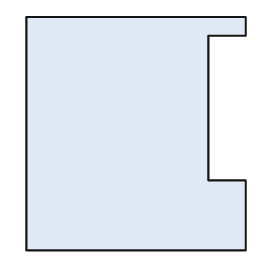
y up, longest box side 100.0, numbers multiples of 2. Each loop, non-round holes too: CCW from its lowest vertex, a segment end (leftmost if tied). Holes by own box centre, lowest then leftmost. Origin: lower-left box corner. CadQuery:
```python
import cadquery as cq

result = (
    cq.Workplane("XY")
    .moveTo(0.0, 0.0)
    .lineTo(94.0, 0.0)
    .lineTo(94.0, 30.0)
    .lineTo(78.0, 30.0)
    .lineTo(78.0, 92.0)
    .lineTo(94.0, 92.0)
    .lineTo(94.0, 100.0)
    .lineTo(0.0, 100.0)
    .close()
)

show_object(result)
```